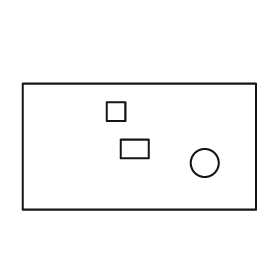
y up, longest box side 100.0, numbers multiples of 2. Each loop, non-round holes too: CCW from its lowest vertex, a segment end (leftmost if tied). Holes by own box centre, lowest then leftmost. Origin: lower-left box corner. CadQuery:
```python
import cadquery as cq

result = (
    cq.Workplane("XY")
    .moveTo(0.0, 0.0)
    .lineTo(100.0, 0.0)
    .lineTo(100.0, 54.0)
    .lineTo(0.0, 54.0)
    .close()
    .moveTo(78.0, 20.0)
    .circle(6.0)
    .moveTo(42.0, 22.0)
    .lineTo(54.0, 22.0)
    .lineTo(54.0, 30.0)
    .lineTo(42.0, 30.0)
    .close()
    .moveTo(36.0, 38.0)
    .lineTo(44.0, 38.0)
    .lineTo(44.0, 46.0)
    .lineTo(36.0, 46.0)
    .close()
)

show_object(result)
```